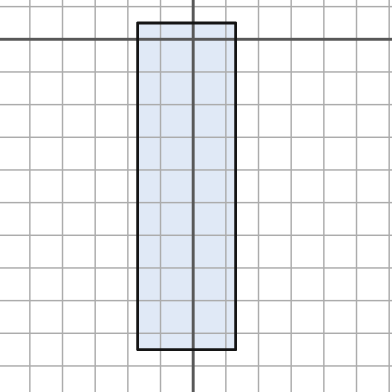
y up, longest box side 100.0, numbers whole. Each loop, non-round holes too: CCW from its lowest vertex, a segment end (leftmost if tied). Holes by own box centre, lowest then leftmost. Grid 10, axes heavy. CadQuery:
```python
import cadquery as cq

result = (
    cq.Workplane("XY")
    .moveTo(-17.0, -95.0)
    .lineTo(13.0, -95.0)
    .lineTo(13.0, 5.0)
    .lineTo(-17.0, 5.0)
    .close()
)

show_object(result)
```